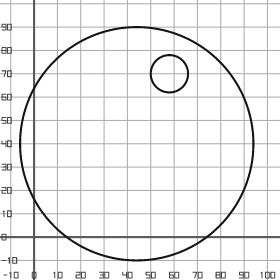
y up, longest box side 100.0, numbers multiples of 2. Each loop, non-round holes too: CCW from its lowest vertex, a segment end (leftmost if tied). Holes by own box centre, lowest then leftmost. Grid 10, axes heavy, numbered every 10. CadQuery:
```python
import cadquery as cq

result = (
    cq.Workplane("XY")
    .moveTo(44.0, 40.0)
    .circle(50.0)
    .moveTo(58.0, 70.0)
    .circle(8.0)
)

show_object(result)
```